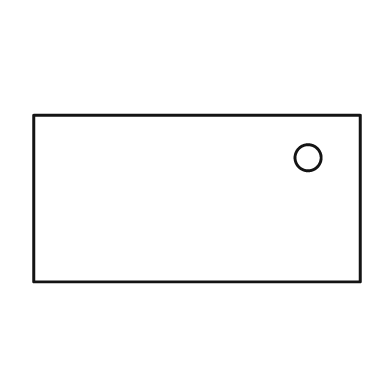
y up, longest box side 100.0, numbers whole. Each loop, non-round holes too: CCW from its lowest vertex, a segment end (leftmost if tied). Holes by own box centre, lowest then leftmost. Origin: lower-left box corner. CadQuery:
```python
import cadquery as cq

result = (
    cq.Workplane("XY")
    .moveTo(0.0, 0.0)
    .lineTo(100.0, 0.0)
    .lineTo(100.0, 51.0)
    .lineTo(0.0, 51.0)
    .close()
    .moveTo(84.0, 38.0)
    .circle(4.0)
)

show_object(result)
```